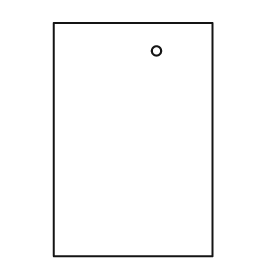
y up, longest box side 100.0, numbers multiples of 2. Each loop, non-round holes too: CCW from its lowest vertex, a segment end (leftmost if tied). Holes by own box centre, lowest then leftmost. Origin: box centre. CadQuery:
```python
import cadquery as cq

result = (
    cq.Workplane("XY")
    .moveTo(-34.0, -50.0)
    .lineTo(34.0, -50.0)
    .lineTo(34.0, 50.0)
    .lineTo(-34.0, 50.0)
    .close()
    .moveTo(10.0, 38.0)
    .circle(2.0)
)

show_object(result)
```